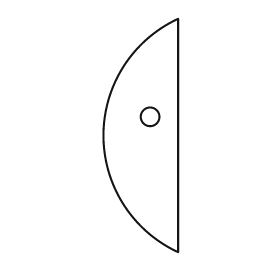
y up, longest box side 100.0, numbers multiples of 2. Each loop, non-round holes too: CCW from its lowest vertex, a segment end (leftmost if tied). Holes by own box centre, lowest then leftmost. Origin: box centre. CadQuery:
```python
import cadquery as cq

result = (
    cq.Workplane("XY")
    .moveTo(16.0, -50.0)
    .lineTo(16.0, 50.0)
    .threePointArc((-16.0, 0.0), (16.0, -50.0))
    .close()
    .moveTo(4.0, 8.0)
    .circle(4.0)
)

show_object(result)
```